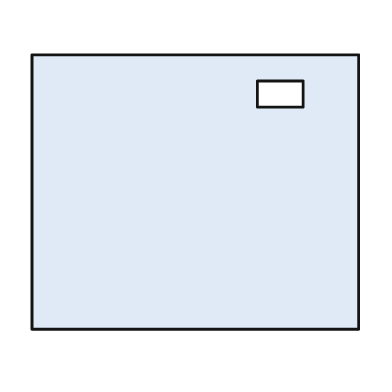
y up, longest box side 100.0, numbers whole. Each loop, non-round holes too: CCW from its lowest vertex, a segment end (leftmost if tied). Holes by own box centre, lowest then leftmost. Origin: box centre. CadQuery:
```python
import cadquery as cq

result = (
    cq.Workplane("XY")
    .moveTo(-50.0, -42.0)
    .lineTo(50.0, -42.0)
    .lineTo(50.0, 42.0)
    .lineTo(-50.0, 42.0)
    .close()
    .moveTo(19.0, 26.0)
    .lineTo(33.0, 26.0)
    .lineTo(33.0, 34.0)
    .lineTo(19.0, 34.0)
    .close()
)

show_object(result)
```